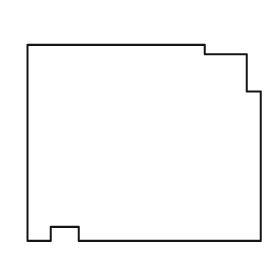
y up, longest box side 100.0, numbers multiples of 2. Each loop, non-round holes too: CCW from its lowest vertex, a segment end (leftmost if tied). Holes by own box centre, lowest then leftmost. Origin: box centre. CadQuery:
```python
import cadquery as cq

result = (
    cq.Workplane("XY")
    .moveTo(-50.0, -42.0)
    .lineTo(-40.0, -42.0)
    .lineTo(-40.0, -36.0)
    .lineTo(-28.0, -36.0)
    .lineTo(-28.0, -42.0)
    .lineTo(50.0, -42.0)
    .lineTo(50.0, 22.0)
    .lineTo(44.0, 22.0)
    .lineTo(44.0, 38.0)
    .lineTo(26.0, 38.0)
    .lineTo(26.0, 42.0)
    .lineTo(-50.0, 42.0)
    .close()
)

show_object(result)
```